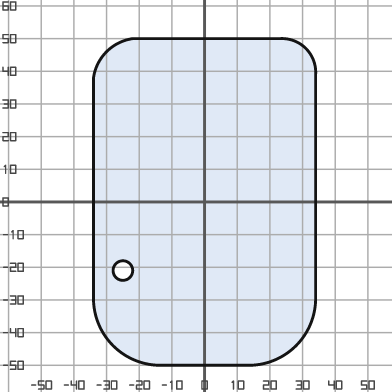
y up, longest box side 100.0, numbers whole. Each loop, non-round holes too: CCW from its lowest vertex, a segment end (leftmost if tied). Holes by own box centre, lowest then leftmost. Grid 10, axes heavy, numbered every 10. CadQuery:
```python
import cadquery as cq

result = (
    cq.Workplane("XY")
    .moveTo(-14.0, -50.0)
    .lineTo(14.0, -50.0)
    .threePointArc((28.0, -44.0), (34.0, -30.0))
    .lineTo(34.0, 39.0)
    .threePointArc((31.0, 47.0), (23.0, 50.0))
    .lineTo(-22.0, 50.0)
    .threePointArc((-30.0, 46.0), (-34.0, 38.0))
    .lineTo(-34.0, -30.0)
    .threePointArc((-28.0, -44.0), (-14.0, -50.0))
    .close()
    .moveTo(-25.0, -21.0)
    .circle(3.0)
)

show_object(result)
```